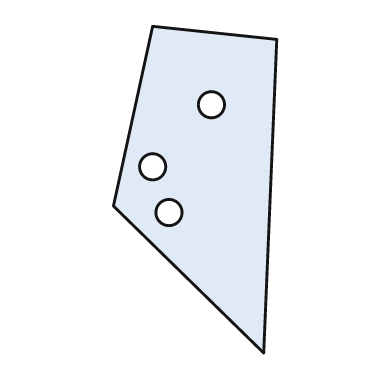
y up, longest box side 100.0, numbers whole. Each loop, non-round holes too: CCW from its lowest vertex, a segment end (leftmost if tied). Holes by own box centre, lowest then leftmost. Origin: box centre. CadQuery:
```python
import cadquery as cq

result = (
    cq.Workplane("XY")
    .moveTo(21.0, -50.0)
    .lineTo(25.0, 46.0)
    .lineTo(-13.0, 50.0)
    .lineTo(-25.0, -5.0)
    .close()
    .moveTo(-8.0, -7.0)
    .circle(4.0)
    .moveTo(-13.0, 7.0)
    .circle(4.0)
    .moveTo(5.0, 26.0)
    .circle(4.0)
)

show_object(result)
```